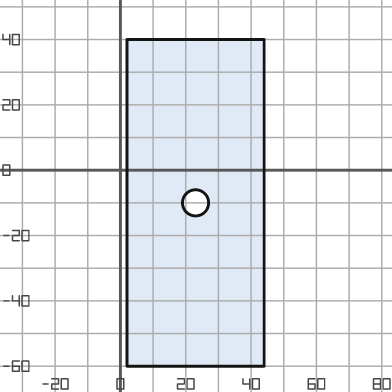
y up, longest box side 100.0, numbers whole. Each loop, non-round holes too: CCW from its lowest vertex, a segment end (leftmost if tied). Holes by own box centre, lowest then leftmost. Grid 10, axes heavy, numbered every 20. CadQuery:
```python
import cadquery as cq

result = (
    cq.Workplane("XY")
    .moveTo(2.0, -60.0)
    .lineTo(44.0, -60.0)
    .lineTo(44.0, 40.0)
    .lineTo(2.0, 40.0)
    .close()
    .moveTo(23.0, -10.0)
    .circle(4.0)
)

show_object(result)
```